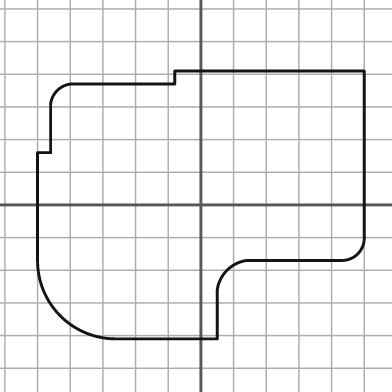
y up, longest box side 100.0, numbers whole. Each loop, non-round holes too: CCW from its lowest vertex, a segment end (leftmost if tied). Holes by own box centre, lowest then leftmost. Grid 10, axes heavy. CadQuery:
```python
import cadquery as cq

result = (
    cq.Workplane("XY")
    .moveTo(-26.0, -41.0)
    .lineTo(5.0, -41.0)
    .lineTo(5.0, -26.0)
    .threePointArc((8.0, -20.0), (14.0, -17.0))
    .lineTo(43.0, -17.0)
    .threePointArc((48.0, -15.0), (50.0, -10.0))
    .lineTo(50.0, 41.0)
    .lineTo(-8.0, 41.0)
    .lineTo(-8.0, 37.0)
    .lineTo(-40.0, 37.0)
    .threePointArc((-44.0, 35.0), (-46.0, 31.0))
    .lineTo(-46.0, 16.0)
    .lineTo(-50.0, 16.0)
    .lineTo(-50.0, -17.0)
    .threePointArc((-43.0, -34.0), (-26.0, -41.0))
    .close()
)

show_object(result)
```